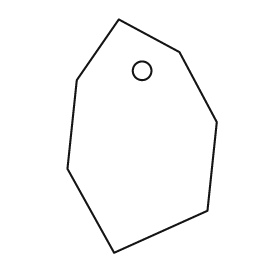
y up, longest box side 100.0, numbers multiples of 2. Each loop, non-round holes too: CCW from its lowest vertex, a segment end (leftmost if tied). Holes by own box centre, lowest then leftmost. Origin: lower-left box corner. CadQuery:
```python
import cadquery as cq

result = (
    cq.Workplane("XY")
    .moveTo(20.0, 0.0)
    .lineTo(60.0, 18.0)
    .lineTo(64.0, 56.0)
    .lineTo(48.0, 86.0)
    .lineTo(22.0, 100.0)
    .lineTo(4.0, 74.0)
    .lineTo(0.0, 36.0)
    .close()
    .moveTo(32.0, 78.0)
    .circle(4.0)
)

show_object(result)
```